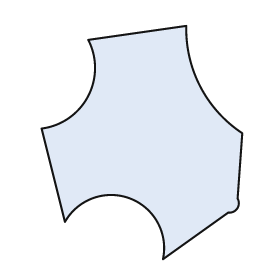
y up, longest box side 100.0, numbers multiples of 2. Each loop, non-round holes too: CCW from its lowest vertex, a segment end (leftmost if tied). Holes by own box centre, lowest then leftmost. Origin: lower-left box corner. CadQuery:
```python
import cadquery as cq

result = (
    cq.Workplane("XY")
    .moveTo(52.0, 0.0)
    .lineTo(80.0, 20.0)
    .threePointArc((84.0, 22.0), (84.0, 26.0))
    .lineTo(86.0, 54.0)
    .threePointArc((68.0, 74.0), (62.0, 100.0))
    .lineTo(20.0, 94.0)
    .threePointArc((20.0, 70.0), (0.0, 56.0))
    .lineTo(10.0, 16.0)
    .threePointArc((38.0, 26.0), (52.0, 0.0))
    .close()
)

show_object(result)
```